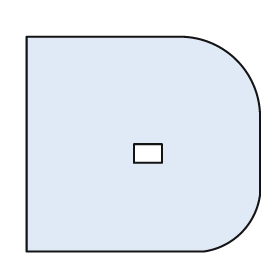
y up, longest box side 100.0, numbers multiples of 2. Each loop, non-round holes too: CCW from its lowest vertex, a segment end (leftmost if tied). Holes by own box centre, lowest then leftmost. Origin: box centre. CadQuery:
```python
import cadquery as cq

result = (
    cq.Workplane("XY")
    .moveTo(-50.0, -46.0)
    .lineTo(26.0, -46.0)
    .threePointArc((42.0, -38.0), (50.0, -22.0))
    .lineTo(50.0, 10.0)
    .threePointArc((40.0, 36.0), (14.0, 46.0))
    .lineTo(-50.0, 46.0)
    .close()
    .moveTo(-4.0, -8.0)
    .lineTo(8.0, -8.0)
    .lineTo(8.0, 0.0)
    .lineTo(-4.0, 0.0)
    .close()
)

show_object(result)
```